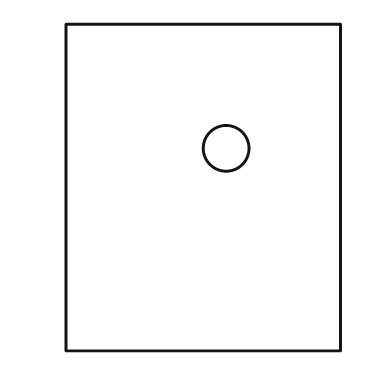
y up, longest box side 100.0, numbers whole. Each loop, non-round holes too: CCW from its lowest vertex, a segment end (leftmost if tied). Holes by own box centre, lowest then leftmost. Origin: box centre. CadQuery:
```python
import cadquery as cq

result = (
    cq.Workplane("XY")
    .moveTo(-42.0, -50.0)
    .lineTo(42.0, -50.0)
    .lineTo(42.0, 50.0)
    .lineTo(-42.0, 50.0)
    .close()
    .moveTo(7.0, 12.0)
    .circle(7.0)
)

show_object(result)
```